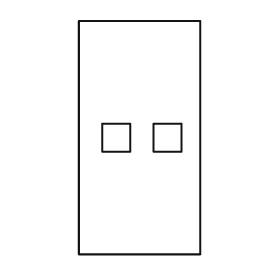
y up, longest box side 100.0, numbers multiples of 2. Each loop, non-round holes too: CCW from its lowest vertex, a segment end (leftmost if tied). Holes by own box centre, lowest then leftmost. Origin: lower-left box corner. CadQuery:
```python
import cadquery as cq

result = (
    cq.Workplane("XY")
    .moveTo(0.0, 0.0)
    .lineTo(52.0, 0.0)
    .lineTo(52.0, 100.0)
    .lineTo(0.0, 100.0)
    .close()
    .moveTo(10.0, 44.0)
    .lineTo(22.0, 44.0)
    .lineTo(22.0, 56.0)
    .lineTo(10.0, 56.0)
    .close()
    .moveTo(32.0, 44.0)
    .lineTo(44.0, 44.0)
    .lineTo(44.0, 56.0)
    .lineTo(32.0, 56.0)
    .close()
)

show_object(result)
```